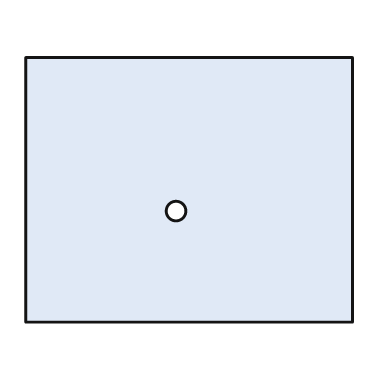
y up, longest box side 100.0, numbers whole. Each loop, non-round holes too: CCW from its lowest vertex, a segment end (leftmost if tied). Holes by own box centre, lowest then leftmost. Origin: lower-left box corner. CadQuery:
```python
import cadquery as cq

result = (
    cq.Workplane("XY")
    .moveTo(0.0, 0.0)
    .lineTo(100.0, 0.0)
    .lineTo(100.0, 81.0)
    .lineTo(0.0, 81.0)
    .close()
    .moveTo(46.0, 34.0)
    .circle(3.0)
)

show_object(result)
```